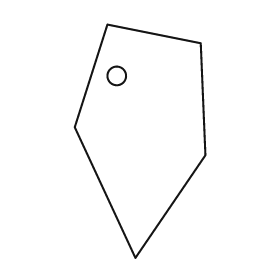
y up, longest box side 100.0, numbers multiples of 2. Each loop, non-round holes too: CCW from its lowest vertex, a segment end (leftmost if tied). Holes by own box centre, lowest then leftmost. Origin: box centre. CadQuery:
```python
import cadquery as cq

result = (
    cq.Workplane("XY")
    .moveTo(-2.0, -50.0)
    .lineTo(28.0, -6.0)
    .lineTo(26.0, 42.0)
    .lineTo(-14.0, 50.0)
    .lineTo(-28.0, 6.0)
    .close()
    .moveTo(-10.0, 28.0)
    .circle(4.0)
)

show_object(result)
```